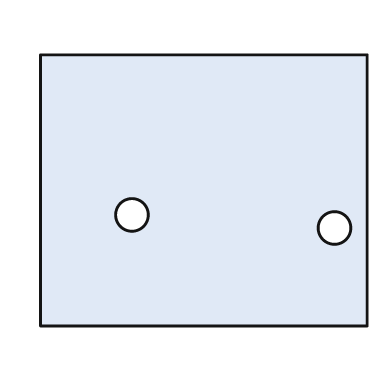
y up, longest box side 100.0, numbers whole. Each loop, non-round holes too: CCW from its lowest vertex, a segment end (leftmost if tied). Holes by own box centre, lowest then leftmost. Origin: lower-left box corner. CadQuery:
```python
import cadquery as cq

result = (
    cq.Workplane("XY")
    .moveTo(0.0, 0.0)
    .lineTo(100.0, 0.0)
    .lineTo(100.0, 83.0)
    .lineTo(0.0, 83.0)
    .close()
    .moveTo(90.0, 30.0)
    .circle(5.0)
    .moveTo(28.0, 34.0)
    .circle(5.0)
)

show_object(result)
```